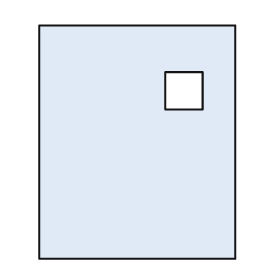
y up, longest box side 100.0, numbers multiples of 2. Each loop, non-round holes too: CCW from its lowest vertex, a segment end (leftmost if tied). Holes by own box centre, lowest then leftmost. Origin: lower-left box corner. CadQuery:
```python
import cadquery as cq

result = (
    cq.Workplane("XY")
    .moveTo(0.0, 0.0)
    .lineTo(84.0, 0.0)
    .lineTo(84.0, 100.0)
    .lineTo(0.0, 100.0)
    .close()
    .moveTo(54.0, 64.0)
    .lineTo(70.0, 64.0)
    .lineTo(70.0, 80.0)
    .lineTo(54.0, 80.0)
    .close()
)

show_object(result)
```